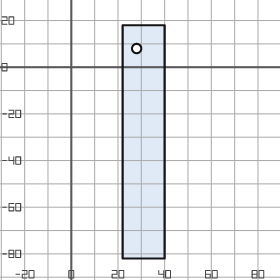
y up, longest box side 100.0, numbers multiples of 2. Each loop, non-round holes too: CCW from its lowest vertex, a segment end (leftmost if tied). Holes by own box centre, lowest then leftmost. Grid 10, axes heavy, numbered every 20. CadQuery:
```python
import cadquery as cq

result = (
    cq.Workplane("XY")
    .moveTo(22.0, -82.0)
    .lineTo(40.0, -82.0)
    .lineTo(40.0, 18.0)
    .lineTo(22.0, 18.0)
    .close()
    .moveTo(28.0, 8.0)
    .circle(2.0)
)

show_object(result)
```